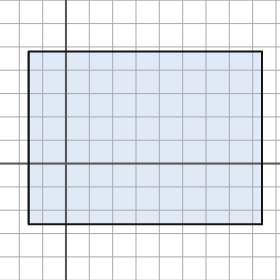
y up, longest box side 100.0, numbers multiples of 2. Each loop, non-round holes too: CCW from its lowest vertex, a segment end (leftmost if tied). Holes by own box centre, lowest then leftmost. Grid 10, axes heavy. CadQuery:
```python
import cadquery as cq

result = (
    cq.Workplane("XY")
    .moveTo(-16.0, -26.0)
    .lineTo(84.0, -26.0)
    .lineTo(84.0, 48.0)
    .lineTo(-16.0, 48.0)
    .close()
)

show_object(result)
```